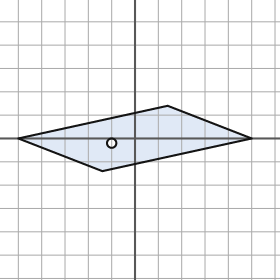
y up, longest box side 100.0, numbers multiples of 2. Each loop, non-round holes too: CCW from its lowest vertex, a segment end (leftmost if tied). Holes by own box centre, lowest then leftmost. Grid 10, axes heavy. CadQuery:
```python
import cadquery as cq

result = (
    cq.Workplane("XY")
    .moveTo(-14.0, -14.0)
    .lineTo(50.0, 0.0)
    .lineTo(14.0, 14.0)
    .lineTo(-50.0, 0.0)
    .close()
    .moveTo(-10.0, -2.0)
    .circle(2.0)
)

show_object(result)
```